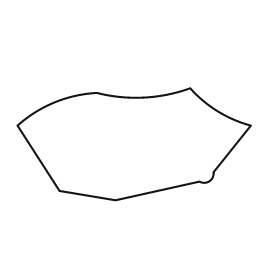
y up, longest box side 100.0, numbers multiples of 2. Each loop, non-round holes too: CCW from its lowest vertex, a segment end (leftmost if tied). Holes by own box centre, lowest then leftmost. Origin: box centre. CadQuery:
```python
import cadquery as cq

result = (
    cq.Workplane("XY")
    .moveTo(-8.0, -24.0)
    .lineTo(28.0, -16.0)
    .threePointArc((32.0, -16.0), (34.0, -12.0))
    .lineTo(50.0, 8.0)
    .threePointArc((36.0, 14.0), (24.0, 24.0))
    .threePointArc((4.0, 20.0), (-16.0, 22.0))
    .threePointArc((-34.0, 18.0), (-50.0, 8.0))
    .lineTo(-32.0, -20.0)
    .close()
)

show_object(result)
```